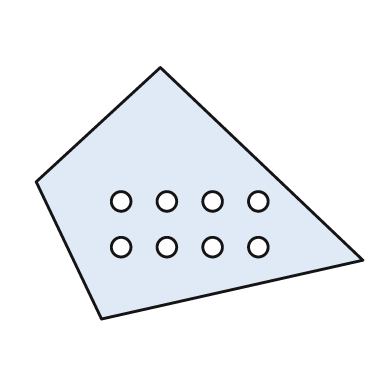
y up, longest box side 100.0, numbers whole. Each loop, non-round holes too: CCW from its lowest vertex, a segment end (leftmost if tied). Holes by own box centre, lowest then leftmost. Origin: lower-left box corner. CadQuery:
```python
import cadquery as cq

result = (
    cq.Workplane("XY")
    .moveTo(20.0, 0.0)
    .lineTo(100.0, 18.0)
    .lineTo(38.0, 77.0)
    .lineTo(0.0, 42.0)
    .close()
    .moveTo(26.0, 22.0)
    .circle(3.0)
    .moveTo(40.0, 22.0)
    .circle(3.0)
    .moveTo(54.0, 22.0)
    .circle(3.0)
    .moveTo(68.0, 22.0)
    .circle(3.0)
    .moveTo(26.0, 36.0)
    .circle(3.0)
    .moveTo(40.0, 36.0)
    .circle(3.0)
    .moveTo(54.0, 36.0)
    .circle(3.0)
    .moveTo(68.0, 36.0)
    .circle(3.0)
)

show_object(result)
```